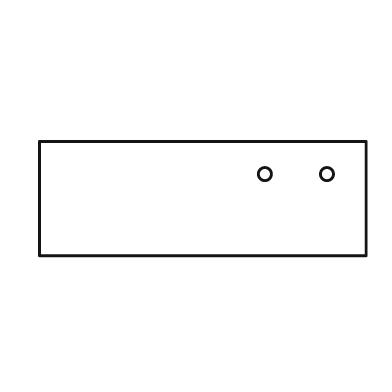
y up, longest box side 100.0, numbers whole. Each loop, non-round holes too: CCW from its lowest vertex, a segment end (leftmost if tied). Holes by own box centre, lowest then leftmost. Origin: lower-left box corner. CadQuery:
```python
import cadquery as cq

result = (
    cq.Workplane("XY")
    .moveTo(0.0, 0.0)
    .lineTo(100.0, 0.0)
    .lineTo(100.0, 35.0)
    .lineTo(0.0, 35.0)
    .close()
    .moveTo(69.0, 25.0)
    .circle(2.0)
    .moveTo(88.0, 25.0)
    .circle(2.0)
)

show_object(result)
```